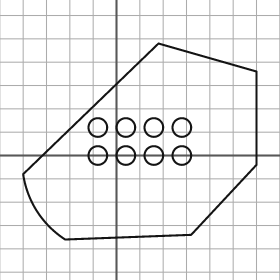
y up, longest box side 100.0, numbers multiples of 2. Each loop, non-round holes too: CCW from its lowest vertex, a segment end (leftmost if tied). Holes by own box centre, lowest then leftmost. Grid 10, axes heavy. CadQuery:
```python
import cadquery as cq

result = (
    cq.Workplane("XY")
    .moveTo(-22.0, -36.0)
    .lineTo(32.0, -34.0)
    .lineTo(60.0, -4.0)
    .lineTo(60.0, 36.0)
    .lineTo(18.0, 48.0)
    .lineTo(-40.0, -8.0)
    .threePointArc((-34.0, -24.0), (-22.0, -36.0))
    .close()
    .moveTo(-8.0, 0.0)
    .circle(4.0)
    .moveTo(4.0, 0.0)
    .circle(4.0)
    .moveTo(16.0, 0.0)
    .circle(4.0)
    .moveTo(28.0, 0.0)
    .circle(4.0)
    .moveTo(-8.0, 12.0)
    .circle(4.0)
    .moveTo(4.0, 12.0)
    .circle(4.0)
    .moveTo(16.0, 12.0)
    .circle(4.0)
    .moveTo(28.0, 12.0)
    .circle(4.0)
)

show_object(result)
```